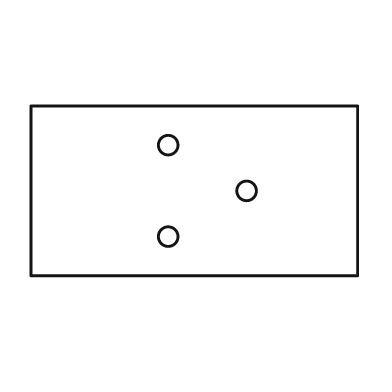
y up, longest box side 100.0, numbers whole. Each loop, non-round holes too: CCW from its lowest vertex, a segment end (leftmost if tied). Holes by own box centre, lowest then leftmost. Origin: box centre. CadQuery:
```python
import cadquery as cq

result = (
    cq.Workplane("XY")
    .moveTo(-50.0, -26.0)
    .lineTo(50.0, -26.0)
    .lineTo(50.0, 26.0)
    .lineTo(-50.0, 26.0)
    .close()
    .moveTo(-8.0, -14.0)
    .circle(3.0)
    .moveTo(16.0, 0.0)
    .circle(3.0)
    .moveTo(-8.0, 14.0)
    .circle(3.0)
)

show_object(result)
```